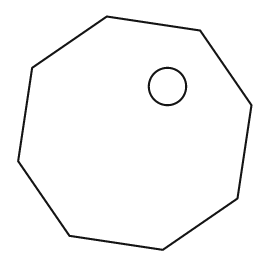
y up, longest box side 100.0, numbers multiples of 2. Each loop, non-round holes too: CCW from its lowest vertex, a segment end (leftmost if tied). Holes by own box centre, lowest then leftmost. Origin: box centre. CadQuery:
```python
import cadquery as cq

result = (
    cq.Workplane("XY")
    .moveTo(12.0, -50.0)
    .lineTo(44.0, -28.0)
    .lineTo(50.0, 12.0)
    .lineTo(28.0, 44.0)
    .lineTo(-12.0, 50.0)
    .lineTo(-44.0, 28.0)
    .lineTo(-50.0, -12.0)
    .lineTo(-28.0, -44.0)
    .close()
    .moveTo(14.0, 20.0)
    .circle(8.0)
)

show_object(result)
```